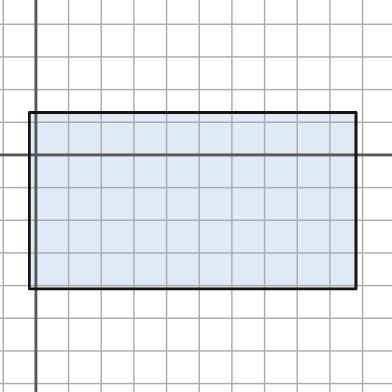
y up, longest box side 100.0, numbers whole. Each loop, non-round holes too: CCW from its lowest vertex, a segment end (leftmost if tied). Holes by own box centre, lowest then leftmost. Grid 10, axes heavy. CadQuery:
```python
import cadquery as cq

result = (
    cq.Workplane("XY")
    .moveTo(-2.0, -41.0)
    .lineTo(98.0, -41.0)
    .lineTo(98.0, 13.0)
    .lineTo(-2.0, 13.0)
    .close()
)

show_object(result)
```